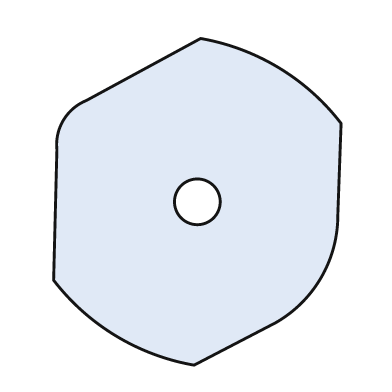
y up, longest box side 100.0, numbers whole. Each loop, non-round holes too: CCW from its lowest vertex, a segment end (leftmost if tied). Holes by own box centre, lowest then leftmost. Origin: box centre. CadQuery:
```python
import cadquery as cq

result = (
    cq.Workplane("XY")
    .moveTo(-1.0, -50.0)
    .lineTo(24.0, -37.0)
    .threePointArc((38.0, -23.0), (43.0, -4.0))
    .lineTo(44.0, 24.0)
    .threePointArc((25.0, 41.0), (1.0, 50.0))
    .lineTo(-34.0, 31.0)
    .threePointArc((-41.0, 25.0), (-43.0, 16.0))
    .lineTo(-44.0, -24.0)
    .threePointArc((-25.0, -41.0), (-1.0, -50.0))
    .close()
    .moveTo(0.0, 0.0)
    .circle(7.0)
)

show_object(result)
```